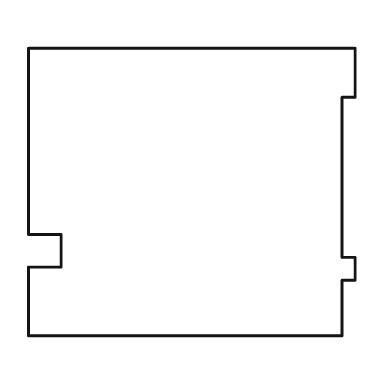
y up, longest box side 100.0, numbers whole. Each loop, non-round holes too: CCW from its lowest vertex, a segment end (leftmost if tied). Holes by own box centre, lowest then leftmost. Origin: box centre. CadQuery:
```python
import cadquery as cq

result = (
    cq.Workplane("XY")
    .moveTo(-50.0, -44.0)
    .lineTo(46.0, -44.0)
    .lineTo(46.0, -27.0)
    .lineTo(50.0, -27.0)
    .lineTo(50.0, -20.0)
    .lineTo(46.0, -20.0)
    .lineTo(46.0, 29.0)
    .lineTo(50.0, 29.0)
    .lineTo(50.0, 44.0)
    .lineTo(-50.0, 44.0)
    .lineTo(-50.0, -13.0)
    .lineTo(-40.0, -13.0)
    .lineTo(-40.0, -23.0)
    .lineTo(-50.0, -23.0)
    .close()
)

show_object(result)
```